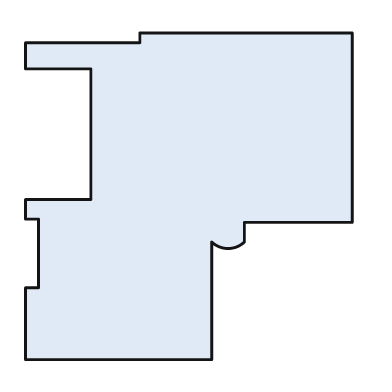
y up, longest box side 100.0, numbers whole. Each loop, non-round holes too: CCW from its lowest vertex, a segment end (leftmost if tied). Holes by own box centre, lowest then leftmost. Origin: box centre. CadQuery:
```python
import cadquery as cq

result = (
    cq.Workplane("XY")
    .moveTo(-50.0, -50.0)
    .lineTo(7.0, -50.0)
    .lineTo(7.0, -14.0)
    .threePointArc((12.0, -16.0), (17.0, -14.0))
    .lineTo(17.0, -8.0)
    .lineTo(50.0, -8.0)
    .lineTo(50.0, 50.0)
    .lineTo(-15.0, 50.0)
    .lineTo(-15.0, 47.0)
    .lineTo(-50.0, 47.0)
    .lineTo(-50.0, 39.0)
    .lineTo(-30.0, 39.0)
    .lineTo(-30.0, -1.0)
    .lineTo(-50.0, -1.0)
    .lineTo(-50.0, -7.0)
    .lineTo(-46.0, -7.0)
    .lineTo(-46.0, -28.0)
    .lineTo(-50.0, -28.0)
    .close()
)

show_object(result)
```